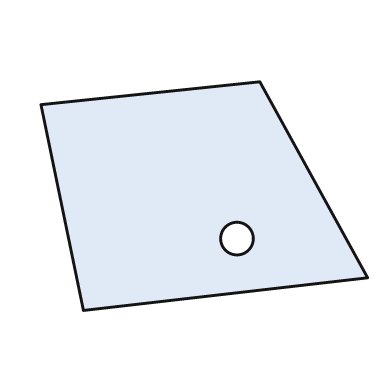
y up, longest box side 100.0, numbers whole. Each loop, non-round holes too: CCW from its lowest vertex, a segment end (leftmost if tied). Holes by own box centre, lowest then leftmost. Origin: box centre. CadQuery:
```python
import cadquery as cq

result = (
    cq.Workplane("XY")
    .moveTo(-37.0, -35.0)
    .lineTo(50.0, -25.0)
    .lineTo(17.0, 35.0)
    .lineTo(-50.0, 28.0)
    .close()
    .moveTo(10.0, -13.0)
    .circle(5.0)
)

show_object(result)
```